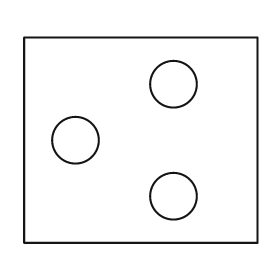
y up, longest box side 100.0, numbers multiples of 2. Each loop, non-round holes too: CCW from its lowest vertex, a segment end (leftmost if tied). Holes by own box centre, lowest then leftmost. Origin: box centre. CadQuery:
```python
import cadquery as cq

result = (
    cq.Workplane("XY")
    .moveTo(-50.0, -44.0)
    .lineTo(50.0, -44.0)
    .lineTo(50.0, 44.0)
    .lineTo(-50.0, 44.0)
    .close()
    .moveTo(14.0, -24.0)
    .circle(10.0)
    .moveTo(-28.0, 0.0)
    .circle(10.0)
    .moveTo(14.0, 24.0)
    .circle(10.0)
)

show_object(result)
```